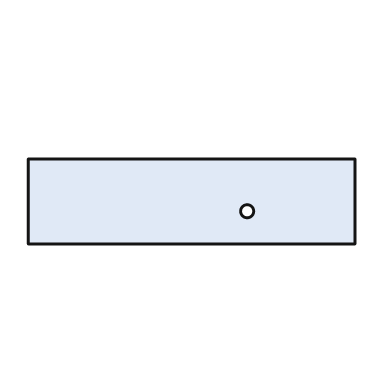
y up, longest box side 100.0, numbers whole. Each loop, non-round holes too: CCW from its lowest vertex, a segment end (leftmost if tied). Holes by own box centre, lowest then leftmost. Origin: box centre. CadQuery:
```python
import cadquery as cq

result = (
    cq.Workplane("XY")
    .moveTo(-50.0, -13.0)
    .lineTo(50.0, -13.0)
    .lineTo(50.0, 13.0)
    .lineTo(-50.0, 13.0)
    .close()
    .moveTo(17.0, -3.0)
    .circle(2.0)
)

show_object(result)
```